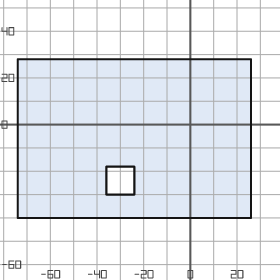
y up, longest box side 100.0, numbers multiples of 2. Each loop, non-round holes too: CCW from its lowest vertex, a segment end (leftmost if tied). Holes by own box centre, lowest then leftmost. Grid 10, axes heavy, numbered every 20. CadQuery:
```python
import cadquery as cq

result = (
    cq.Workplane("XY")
    .moveTo(-74.0, -40.0)
    .lineTo(26.0, -40.0)
    .lineTo(26.0, 28.0)
    .lineTo(-74.0, 28.0)
    .close()
    .moveTo(-36.0, -30.0)
    .lineTo(-24.0, -30.0)
    .lineTo(-24.0, -18.0)
    .lineTo(-36.0, -18.0)
    .close()
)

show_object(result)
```